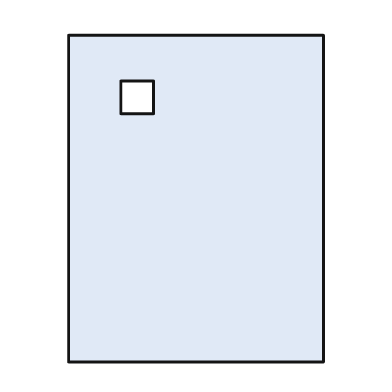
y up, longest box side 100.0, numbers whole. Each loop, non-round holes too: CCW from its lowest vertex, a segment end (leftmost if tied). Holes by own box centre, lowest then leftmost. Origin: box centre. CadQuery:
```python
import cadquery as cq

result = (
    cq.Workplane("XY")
    .moveTo(-39.0, -50.0)
    .lineTo(39.0, -50.0)
    .lineTo(39.0, 50.0)
    .lineTo(-39.0, 50.0)
    .close()
    .moveTo(-23.0, 26.0)
    .lineTo(-13.0, 26.0)
    .lineTo(-13.0, 36.0)
    .lineTo(-23.0, 36.0)
    .close()
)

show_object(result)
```